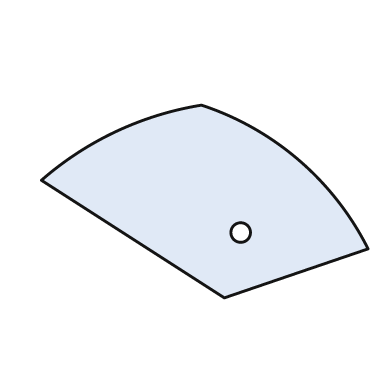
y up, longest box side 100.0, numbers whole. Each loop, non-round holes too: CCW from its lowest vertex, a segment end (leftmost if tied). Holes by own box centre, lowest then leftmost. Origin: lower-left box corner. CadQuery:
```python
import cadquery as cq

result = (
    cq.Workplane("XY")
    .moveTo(56.0, 0.0)
    .lineTo(100.0, 15.0)
    .threePointArc((79.0, 42.0), (49.0, 59.0))
    .threePointArc((23.0, 51.0), (0.0, 36.0))
    .close()
    .moveTo(61.0, 20.0)
    .circle(3.0)
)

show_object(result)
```